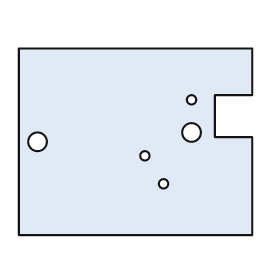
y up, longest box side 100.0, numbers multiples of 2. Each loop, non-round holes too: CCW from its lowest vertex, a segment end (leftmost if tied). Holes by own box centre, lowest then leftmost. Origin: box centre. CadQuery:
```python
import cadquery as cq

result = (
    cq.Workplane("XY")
    .moveTo(-50.0, -40.0)
    .lineTo(50.0, -40.0)
    .lineTo(50.0, 2.0)
    .lineTo(34.0, 2.0)
    .lineTo(34.0, 20.0)
    .lineTo(50.0, 20.0)
    .lineTo(50.0, 40.0)
    .lineTo(-50.0, 40.0)
    .close()
    .moveTo(12.0, -18.0)
    .circle(2.0)
    .moveTo(4.0, -6.0)
    .circle(2.0)
    .moveTo(-42.0, 0.0)
    .circle(4.0)
    .moveTo(24.0, 4.0)
    .circle(4.0)
    .moveTo(24.0, 18.0)
    .circle(2.0)
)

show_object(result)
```